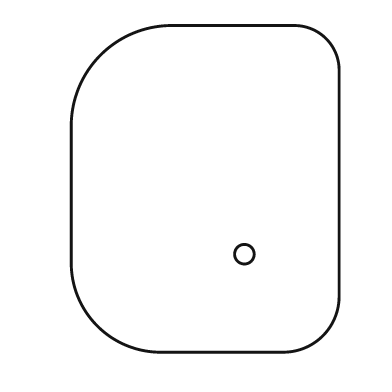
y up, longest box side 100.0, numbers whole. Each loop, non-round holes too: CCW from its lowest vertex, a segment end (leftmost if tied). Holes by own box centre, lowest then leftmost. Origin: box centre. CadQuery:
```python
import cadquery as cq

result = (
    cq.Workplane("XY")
    .moveTo(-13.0, -50.0)
    .lineTo(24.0, -50.0)
    .threePointArc((36.0, -45.0), (41.0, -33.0))
    .lineTo(41.0, 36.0)
    .threePointArc((37.0, 46.0), (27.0, 50.0))
    .lineTo(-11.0, 50.0)
    .threePointArc((-32.0, 41.0), (-41.0, 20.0))
    .lineTo(-41.0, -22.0)
    .threePointArc((-33.0, -42.0), (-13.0, -50.0))
    .close()
    .moveTo(12.0, -20.0)
    .circle(3.0)
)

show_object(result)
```